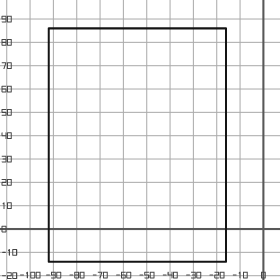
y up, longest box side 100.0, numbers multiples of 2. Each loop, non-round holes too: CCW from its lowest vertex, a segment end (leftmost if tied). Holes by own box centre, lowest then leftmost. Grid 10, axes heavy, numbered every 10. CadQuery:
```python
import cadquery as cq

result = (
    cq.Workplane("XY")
    .moveTo(-92.0, -14.0)
    .lineTo(-16.0, -14.0)
    .lineTo(-16.0, 86.0)
    .lineTo(-92.0, 86.0)
    .close()
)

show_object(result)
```